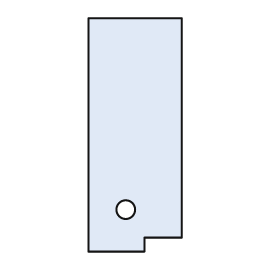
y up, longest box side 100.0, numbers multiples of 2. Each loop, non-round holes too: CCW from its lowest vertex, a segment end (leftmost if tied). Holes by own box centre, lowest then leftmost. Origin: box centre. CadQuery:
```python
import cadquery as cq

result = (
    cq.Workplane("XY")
    .moveTo(-20.0, -50.0)
    .lineTo(4.0, -50.0)
    .lineTo(4.0, -44.0)
    .lineTo(20.0, -44.0)
    .lineTo(20.0, 50.0)
    .lineTo(-20.0, 50.0)
    .close()
    .moveTo(-4.0, -32.0)
    .circle(4.0)
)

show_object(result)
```